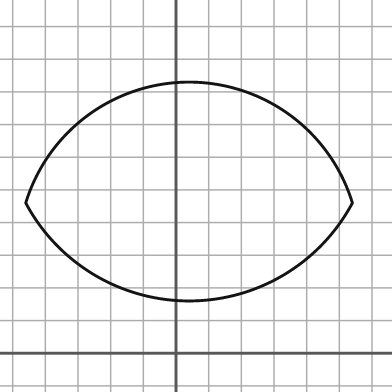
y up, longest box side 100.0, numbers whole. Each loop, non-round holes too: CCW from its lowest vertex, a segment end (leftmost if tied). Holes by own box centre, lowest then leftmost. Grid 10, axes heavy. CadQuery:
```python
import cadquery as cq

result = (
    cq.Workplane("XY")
    .moveTo(-46.0, 46.0)
    .threePointArc((4.0, 16.0), (54.0, 46.0))
    .threePointArc((4.0, 83.0), (-46.0, 46.0))
    .close()
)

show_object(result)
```